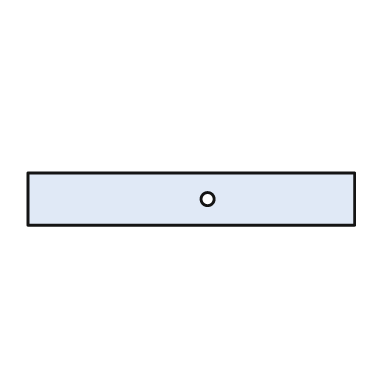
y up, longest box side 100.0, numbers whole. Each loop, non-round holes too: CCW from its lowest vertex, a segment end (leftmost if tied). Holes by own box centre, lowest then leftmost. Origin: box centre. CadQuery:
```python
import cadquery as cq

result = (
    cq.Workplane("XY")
    .moveTo(-50.0, -8.0)
    .lineTo(50.0, -8.0)
    .lineTo(50.0, 8.0)
    .lineTo(-50.0, 8.0)
    .close()
    .moveTo(5.0, 0.0)
    .circle(2.0)
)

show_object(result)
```